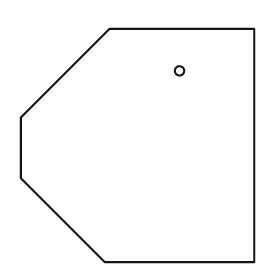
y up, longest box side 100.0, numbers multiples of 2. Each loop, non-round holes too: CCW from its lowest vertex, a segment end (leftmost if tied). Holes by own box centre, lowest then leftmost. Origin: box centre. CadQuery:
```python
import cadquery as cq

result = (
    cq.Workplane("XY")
    .moveTo(-14.0, -50.0)
    .lineTo(50.0, -50.0)
    .lineTo(50.0, 50.0)
    .lineTo(-12.0, 50.0)
    .lineTo(-50.0, 12.0)
    .lineTo(-50.0, -14.0)
    .close()
    .moveTo(18.0, 32.0)
    .circle(2.0)
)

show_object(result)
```